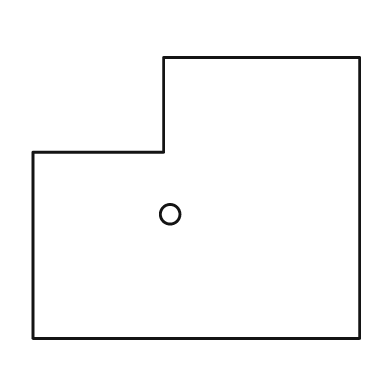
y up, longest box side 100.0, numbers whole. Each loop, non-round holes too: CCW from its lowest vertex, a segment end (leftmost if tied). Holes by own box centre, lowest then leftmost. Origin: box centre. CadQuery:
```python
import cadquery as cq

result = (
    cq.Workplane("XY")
    .moveTo(-50.0, -43.0)
    .lineTo(50.0, -43.0)
    .lineTo(50.0, 43.0)
    .lineTo(-10.0, 43.0)
    .lineTo(-10.0, 14.0)
    .lineTo(-50.0, 14.0)
    .close()
    .moveTo(-8.0, -5.0)
    .circle(3.0)
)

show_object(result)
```